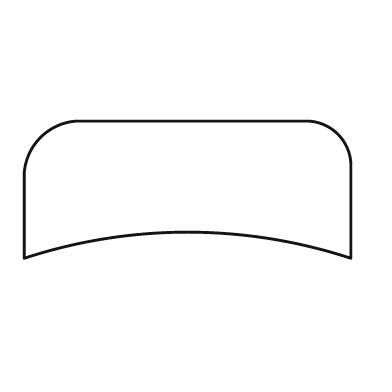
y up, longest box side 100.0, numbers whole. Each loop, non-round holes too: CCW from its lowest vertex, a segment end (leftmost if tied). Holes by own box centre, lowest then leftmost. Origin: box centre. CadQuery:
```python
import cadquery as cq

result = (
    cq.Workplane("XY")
    .moveTo(-50.0, -21.0)
    .threePointArc((0.0, -13.0), (50.0, -21.0))
    .lineTo(50.0, 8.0)
    .threePointArc((46.0, 17.0), (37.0, 21.0))
    .lineTo(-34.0, 21.0)
    .threePointArc((-45.0, 16.0), (-50.0, 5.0))
    .close()
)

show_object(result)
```